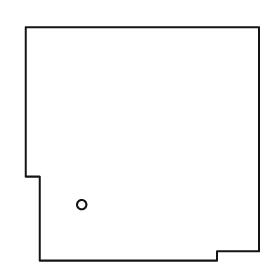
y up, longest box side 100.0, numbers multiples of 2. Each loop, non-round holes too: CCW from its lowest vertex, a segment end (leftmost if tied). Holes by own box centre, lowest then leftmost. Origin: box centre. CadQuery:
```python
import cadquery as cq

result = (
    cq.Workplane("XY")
    .moveTo(-44.0, -50.0)
    .lineTo(32.0, -50.0)
    .lineTo(32.0, -46.0)
    .lineTo(50.0, -46.0)
    .lineTo(50.0, 50.0)
    .lineTo(-50.0, 50.0)
    .lineTo(-50.0, -14.0)
    .lineTo(-44.0, -14.0)
    .close()
    .moveTo(-26.0, -26.0)
    .circle(2.0)
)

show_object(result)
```